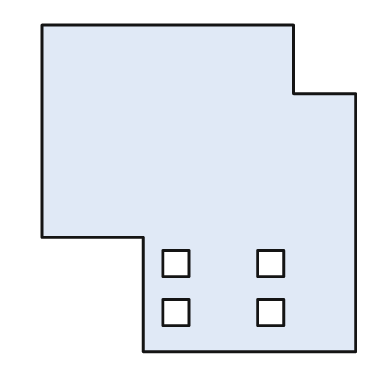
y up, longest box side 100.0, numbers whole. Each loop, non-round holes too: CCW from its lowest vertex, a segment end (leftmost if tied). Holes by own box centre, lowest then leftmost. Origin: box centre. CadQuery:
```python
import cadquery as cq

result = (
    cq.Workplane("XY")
    .moveTo(-17.0, -50.0)
    .lineTo(48.0, -50.0)
    .lineTo(48.0, 29.0)
    .lineTo(29.0, 29.0)
    .lineTo(29.0, 50.0)
    .lineTo(-48.0, 50.0)
    .lineTo(-48.0, -15.0)
    .lineTo(-17.0, -15.0)
    .close()
    .moveTo(-11.0, -42.0)
    .lineTo(-3.0, -42.0)
    .lineTo(-3.0, -34.0)
    .lineTo(-11.0, -34.0)
    .close()
    .moveTo(18.0, -42.0)
    .lineTo(26.0, -42.0)
    .lineTo(26.0, -34.0)
    .lineTo(18.0, -34.0)
    .close()
    .moveTo(-11.0, -27.0)
    .lineTo(-3.0, -27.0)
    .lineTo(-3.0, -19.0)
    .lineTo(-11.0, -19.0)
    .close()
    .moveTo(18.0, -27.0)
    .lineTo(26.0, -27.0)
    .lineTo(26.0, -19.0)
    .lineTo(18.0, -19.0)
    .close()
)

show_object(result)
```